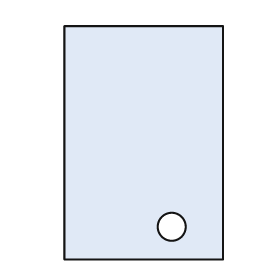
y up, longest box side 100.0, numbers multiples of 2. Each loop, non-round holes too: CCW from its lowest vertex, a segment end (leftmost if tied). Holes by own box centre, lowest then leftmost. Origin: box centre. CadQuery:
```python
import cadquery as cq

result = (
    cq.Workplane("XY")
    .moveTo(-34.0, -50.0)
    .lineTo(34.0, -50.0)
    .lineTo(34.0, 50.0)
    .lineTo(-34.0, 50.0)
    .close()
    .moveTo(12.0, -36.0)
    .circle(6.0)
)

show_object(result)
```